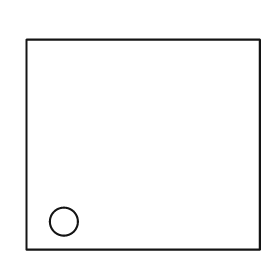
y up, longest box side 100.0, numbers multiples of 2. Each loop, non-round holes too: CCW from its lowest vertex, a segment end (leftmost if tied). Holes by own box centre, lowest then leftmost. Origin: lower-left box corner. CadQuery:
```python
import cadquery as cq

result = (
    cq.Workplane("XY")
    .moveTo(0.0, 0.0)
    .lineTo(100.0, 0.0)
    .lineTo(100.0, 90.0)
    .lineTo(0.0, 90.0)
    .close()
    .moveTo(16.0, 12.0)
    .circle(6.0)
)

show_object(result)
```